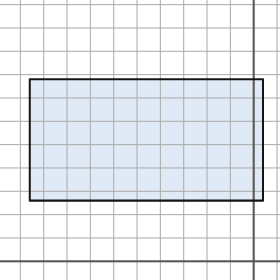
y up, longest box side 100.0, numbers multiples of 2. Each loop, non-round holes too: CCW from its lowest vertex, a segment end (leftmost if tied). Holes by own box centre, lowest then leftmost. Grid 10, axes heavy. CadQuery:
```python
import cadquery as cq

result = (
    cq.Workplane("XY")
    .moveTo(-96.0, 26.0)
    .lineTo(4.0, 26.0)
    .lineTo(4.0, 78.0)
    .lineTo(-96.0, 78.0)
    .close()
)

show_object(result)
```